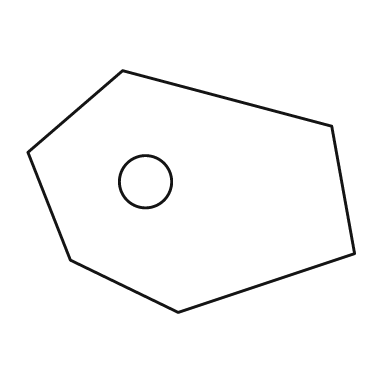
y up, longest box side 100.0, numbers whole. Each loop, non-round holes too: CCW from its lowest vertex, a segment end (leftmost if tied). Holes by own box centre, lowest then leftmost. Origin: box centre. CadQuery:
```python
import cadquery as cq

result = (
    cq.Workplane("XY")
    .moveTo(-4.0, -37.0)
    .lineTo(50.0, -19.0)
    .lineTo(43.0, 20.0)
    .lineTo(-21.0, 37.0)
    .lineTo(-50.0, 12.0)
    .lineTo(-37.0, -21.0)
    .close()
    .moveTo(-14.0, 3.0)
    .circle(8.0)
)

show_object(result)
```